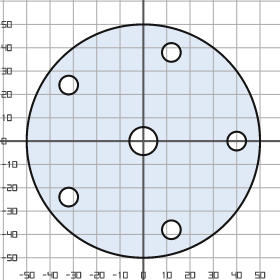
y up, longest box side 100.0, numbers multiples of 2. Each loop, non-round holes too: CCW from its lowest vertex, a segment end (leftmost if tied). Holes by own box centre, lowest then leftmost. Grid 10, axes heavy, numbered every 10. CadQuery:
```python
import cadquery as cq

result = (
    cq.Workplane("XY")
    .moveTo(0.0, 0.0)
    .circle(50.0)
    .moveTo(12.0, -38.0)
    .circle(4.0)
    .moveTo(-32.0, -24.0)
    .circle(4.0)
    .moveTo(0.0, 0.0)
    .circle(6.0)
    .moveTo(40.0, 0.0)
    .circle(4.0)
    .moveTo(-32.0, 24.0)
    .circle(4.0)
    .moveTo(12.0, 38.0)
    .circle(4.0)
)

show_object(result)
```